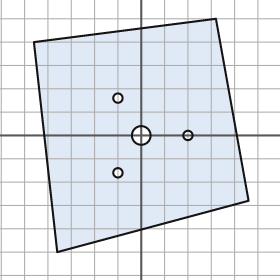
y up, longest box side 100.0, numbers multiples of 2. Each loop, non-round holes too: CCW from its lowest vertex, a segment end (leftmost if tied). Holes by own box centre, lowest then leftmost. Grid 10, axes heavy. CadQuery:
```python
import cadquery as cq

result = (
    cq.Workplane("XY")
    .moveTo(-36.0, -50.0)
    .lineTo(46.0, -28.0)
    .lineTo(32.0, 50.0)
    .lineTo(-46.0, 40.0)
    .close()
    .moveTo(-10.0, -16.0)
    .circle(2.0)
    .moveTo(0.0, 0.0)
    .circle(4.0)
    .moveTo(20.0, 0.0)
    .circle(2.0)
    .moveTo(-10.0, 16.0)
    .circle(2.0)
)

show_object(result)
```